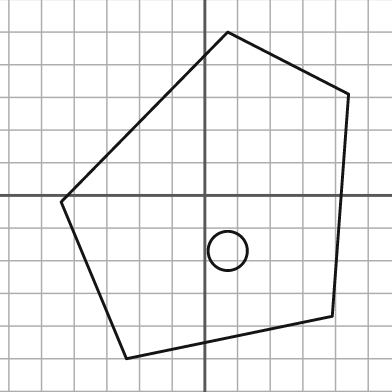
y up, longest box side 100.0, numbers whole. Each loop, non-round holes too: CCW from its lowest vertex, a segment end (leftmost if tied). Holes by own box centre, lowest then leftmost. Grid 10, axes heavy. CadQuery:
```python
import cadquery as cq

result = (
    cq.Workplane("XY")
    .moveTo(-24.0, -50.0)
    .lineTo(39.0, -37.0)
    .lineTo(44.0, 31.0)
    .lineTo(7.0, 50.0)
    .lineTo(-44.0, -2.0)
    .close()
    .moveTo(7.0, -17.0)
    .circle(6.0)
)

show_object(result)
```